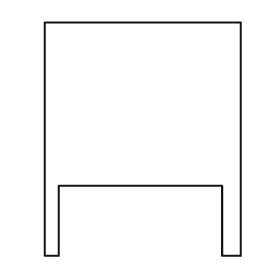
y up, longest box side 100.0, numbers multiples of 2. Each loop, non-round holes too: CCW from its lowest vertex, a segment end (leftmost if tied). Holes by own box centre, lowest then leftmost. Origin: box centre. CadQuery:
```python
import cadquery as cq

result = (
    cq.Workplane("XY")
    .moveTo(-42.0, -50.0)
    .lineTo(-36.0, -50.0)
    .lineTo(-36.0, -20.0)
    .lineTo(34.0, -20.0)
    .lineTo(34.0, -50.0)
    .lineTo(42.0, -50.0)
    .lineTo(42.0, 50.0)
    .lineTo(-42.0, 50.0)
    .close()
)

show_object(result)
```